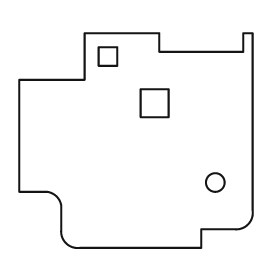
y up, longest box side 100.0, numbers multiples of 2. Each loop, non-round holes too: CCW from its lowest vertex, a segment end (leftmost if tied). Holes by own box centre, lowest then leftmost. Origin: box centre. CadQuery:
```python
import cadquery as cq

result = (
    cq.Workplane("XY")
    .moveTo(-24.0, -46.0)
    .lineTo(28.0, -46.0)
    .lineTo(28.0, -38.0)
    .lineTo(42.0, -38.0)
    .threePointArc((48.0, -36.0), (50.0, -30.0))
    .lineTo(50.0, 46.0)
    .lineTo(46.0, 46.0)
    .lineTo(46.0, 38.0)
    .lineTo(10.0, 38.0)
    .lineTo(10.0, 46.0)
    .lineTo(-22.0, 46.0)
    .lineTo(-22.0, 26.0)
    .lineTo(-50.0, 26.0)
    .lineTo(-50.0, -22.0)
    .lineTo(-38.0, -22.0)
    .threePointArc((-34.0, -24.0), (-32.0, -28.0))
    .lineTo(-32.0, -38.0)
    .threePointArc((-30.0, -44.0), (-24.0, -46.0))
    .close()
    .moveTo(34.0, -18.0)
    .circle(4.0)
    .moveTo(2.0, 10.0)
    .lineTo(14.0, 10.0)
    .lineTo(14.0, 22.0)
    .lineTo(2.0, 22.0)
    .close()
    .moveTo(-16.0, 32.0)
    .lineTo(-8.0, 32.0)
    .lineTo(-8.0, 40.0)
    .lineTo(-16.0, 40.0)
    .close()
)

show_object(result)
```